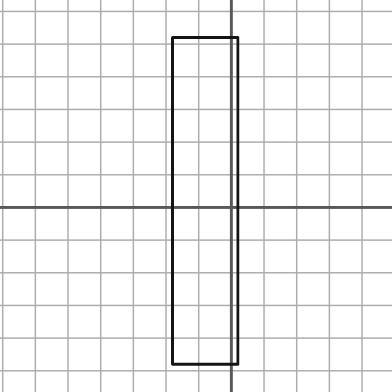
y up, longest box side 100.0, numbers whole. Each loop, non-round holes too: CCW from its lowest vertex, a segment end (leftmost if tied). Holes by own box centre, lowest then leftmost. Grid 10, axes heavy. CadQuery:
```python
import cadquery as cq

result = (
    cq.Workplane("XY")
    .moveTo(-18.0, -48.0)
    .lineTo(2.0, -48.0)
    .lineTo(2.0, 52.0)
    .lineTo(-18.0, 52.0)
    .close()
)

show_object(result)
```